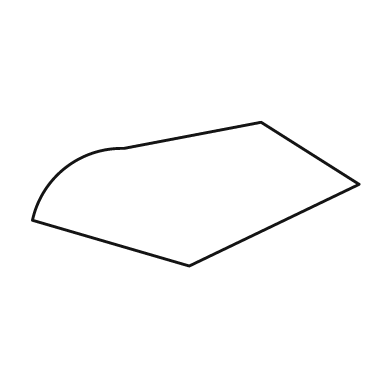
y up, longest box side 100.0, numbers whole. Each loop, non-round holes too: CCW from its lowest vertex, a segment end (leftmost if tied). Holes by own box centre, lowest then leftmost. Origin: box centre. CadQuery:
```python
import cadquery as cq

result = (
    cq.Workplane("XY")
    .moveTo(-2.0, -22.0)
    .lineTo(50.0, 3.0)
    .lineTo(20.0, 22.0)
    .lineTo(-22.0, 14.0)
    .threePointArc((-40.0, 8.0), (-50.0, -8.0))
    .close()
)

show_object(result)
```